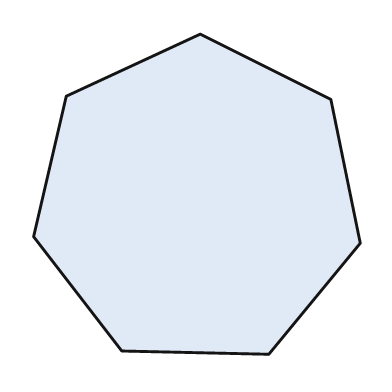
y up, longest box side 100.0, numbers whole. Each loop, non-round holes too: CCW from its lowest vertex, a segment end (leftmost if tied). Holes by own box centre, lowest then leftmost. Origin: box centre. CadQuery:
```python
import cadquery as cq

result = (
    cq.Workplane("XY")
    .moveTo(22.0, -49.0)
    .lineTo(50.0, -15.0)
    .lineTo(41.0, 29.0)
    .lineTo(1.0, 49.0)
    .lineTo(-40.0, 30.0)
    .lineTo(-50.0, -13.0)
    .lineTo(-23.0, -48.0)
    .close()
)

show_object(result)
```